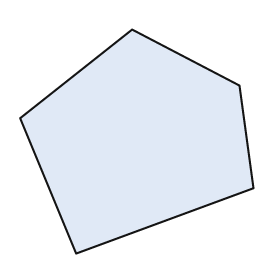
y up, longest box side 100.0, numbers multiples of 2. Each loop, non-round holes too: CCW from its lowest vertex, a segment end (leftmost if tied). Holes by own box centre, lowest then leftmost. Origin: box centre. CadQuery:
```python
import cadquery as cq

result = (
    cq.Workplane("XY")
    .moveTo(-26.0, -48.0)
    .lineTo(50.0, -20.0)
    .lineTo(44.0, 24.0)
    .lineTo(-2.0, 48.0)
    .lineTo(-50.0, 10.0)
    .close()
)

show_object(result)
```